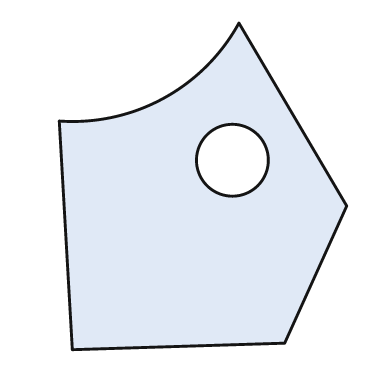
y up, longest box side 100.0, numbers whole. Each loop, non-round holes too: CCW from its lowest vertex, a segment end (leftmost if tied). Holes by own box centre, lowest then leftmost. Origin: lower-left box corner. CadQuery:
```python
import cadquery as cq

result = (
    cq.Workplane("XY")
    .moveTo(4.0, 0.0)
    .lineTo(69.0, 2.0)
    .lineTo(88.0, 44.0)
    .lineTo(55.0, 100.0)
    .threePointArc((32.0, 77.0), (0.0, 70.0))
    .close()
    .moveTo(53.0, 58.0)
    .circle(11.0)
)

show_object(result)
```